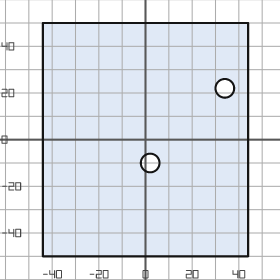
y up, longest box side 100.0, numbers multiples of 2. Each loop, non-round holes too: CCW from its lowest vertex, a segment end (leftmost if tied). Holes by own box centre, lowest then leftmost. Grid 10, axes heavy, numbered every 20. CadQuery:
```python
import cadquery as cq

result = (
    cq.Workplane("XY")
    .moveTo(-44.0, -50.0)
    .lineTo(44.0, -50.0)
    .lineTo(44.0, 50.0)
    .lineTo(-44.0, 50.0)
    .close()
    .moveTo(2.0, -10.0)
    .circle(4.0)
    .moveTo(34.0, 22.0)
    .circle(4.0)
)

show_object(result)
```